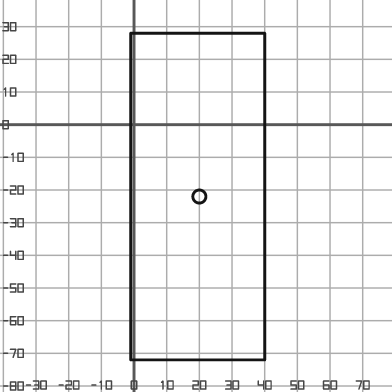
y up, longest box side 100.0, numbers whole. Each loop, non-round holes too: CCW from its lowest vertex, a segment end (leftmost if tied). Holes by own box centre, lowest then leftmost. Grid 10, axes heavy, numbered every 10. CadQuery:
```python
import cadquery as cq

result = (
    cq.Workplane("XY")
    .moveTo(-1.0, -72.0)
    .lineTo(40.0, -72.0)
    .lineTo(40.0, 28.0)
    .lineTo(-1.0, 28.0)
    .close()
    .moveTo(20.0, -22.0)
    .circle(2.0)
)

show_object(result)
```